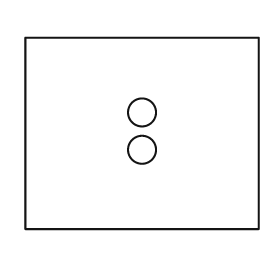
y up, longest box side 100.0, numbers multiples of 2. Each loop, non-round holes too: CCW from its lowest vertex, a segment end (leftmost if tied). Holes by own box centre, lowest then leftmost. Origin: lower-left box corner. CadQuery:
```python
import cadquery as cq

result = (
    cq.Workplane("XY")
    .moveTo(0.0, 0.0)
    .lineTo(100.0, 0.0)
    .lineTo(100.0, 82.0)
    .lineTo(0.0, 82.0)
    .close()
    .moveTo(50.0, 34.0)
    .circle(6.0)
    .moveTo(50.0, 50.0)
    .circle(6.0)
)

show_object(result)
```